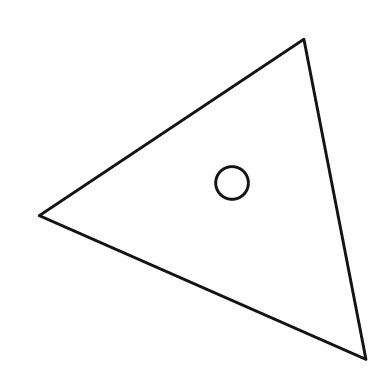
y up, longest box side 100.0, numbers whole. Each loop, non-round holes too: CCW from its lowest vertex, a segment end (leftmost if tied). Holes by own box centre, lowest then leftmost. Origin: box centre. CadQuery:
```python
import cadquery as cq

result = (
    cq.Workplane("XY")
    .moveTo(50.0, -49.0)
    .lineTo(31.0, 49.0)
    .lineTo(-50.0, -5.0)
    .close()
    .moveTo(9.0, 5.0)
    .circle(5.0)
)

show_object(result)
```